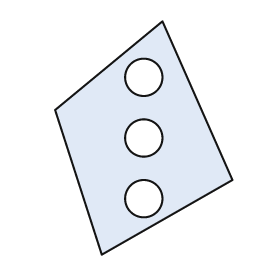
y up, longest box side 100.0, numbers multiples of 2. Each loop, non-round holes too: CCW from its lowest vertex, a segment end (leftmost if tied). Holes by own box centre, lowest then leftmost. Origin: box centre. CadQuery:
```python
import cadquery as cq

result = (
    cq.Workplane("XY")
    .moveTo(-18.0, -50.0)
    .lineTo(38.0, -18.0)
    .lineTo(8.0, 50.0)
    .lineTo(-38.0, 12.0)
    .close()
    .moveTo(0.0, -26.0)
    .circle(8.0)
    .moveTo(0.0, 0.0)
    .circle(8.0)
    .moveTo(0.0, 26.0)
    .circle(8.0)
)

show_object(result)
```